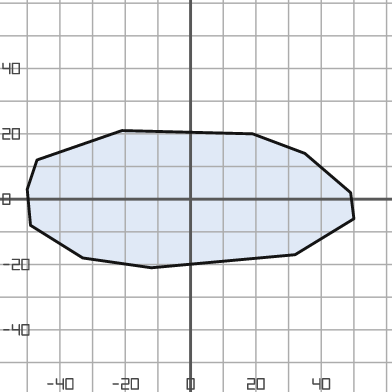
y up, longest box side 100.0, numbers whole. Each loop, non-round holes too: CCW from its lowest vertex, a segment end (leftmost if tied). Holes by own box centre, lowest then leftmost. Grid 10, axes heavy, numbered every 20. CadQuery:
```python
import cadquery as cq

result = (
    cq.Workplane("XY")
    .moveTo(-12.0, -21.0)
    .lineTo(32.0, -17.0)
    .lineTo(50.0, -6.0)
    .lineTo(49.0, 2.0)
    .lineTo(35.0, 14.0)
    .lineTo(19.0, 20.0)
    .lineTo(-21.0, 21.0)
    .lineTo(-47.0, 12.0)
    .lineTo(-50.0, 3.0)
    .lineTo(-49.0, -8.0)
    .lineTo(-33.0, -18.0)
    .close()
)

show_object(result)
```